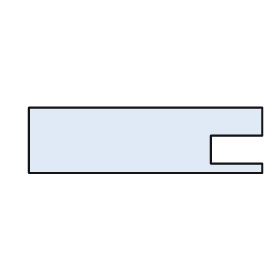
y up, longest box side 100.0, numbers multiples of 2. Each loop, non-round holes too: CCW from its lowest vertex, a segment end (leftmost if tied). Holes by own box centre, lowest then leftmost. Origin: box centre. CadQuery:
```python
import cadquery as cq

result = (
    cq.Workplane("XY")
    .moveTo(-50.0, -14.0)
    .lineTo(50.0, -14.0)
    .lineTo(50.0, -10.0)
    .lineTo(28.0, -10.0)
    .lineTo(28.0, 2.0)
    .lineTo(50.0, 2.0)
    .lineTo(50.0, 14.0)
    .lineTo(-50.0, 14.0)
    .close()
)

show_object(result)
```